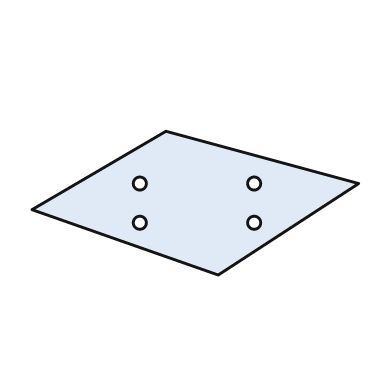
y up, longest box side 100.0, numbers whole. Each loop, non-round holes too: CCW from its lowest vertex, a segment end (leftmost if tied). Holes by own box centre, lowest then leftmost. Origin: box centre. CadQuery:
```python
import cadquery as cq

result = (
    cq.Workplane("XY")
    .moveTo(7.0, -22.0)
    .lineTo(50.0, 6.0)
    .lineTo(-9.0, 22.0)
    .lineTo(-50.0, -2.0)
    .close()
    .moveTo(-17.0, -6.0)
    .circle(2.0)
    .moveTo(18.0, -6.0)
    .circle(2.0)
    .moveTo(-17.0, 6.0)
    .circle(2.0)
    .moveTo(18.0, 6.0)
    .circle(2.0)
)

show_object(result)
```